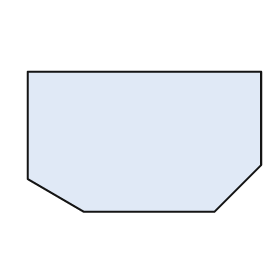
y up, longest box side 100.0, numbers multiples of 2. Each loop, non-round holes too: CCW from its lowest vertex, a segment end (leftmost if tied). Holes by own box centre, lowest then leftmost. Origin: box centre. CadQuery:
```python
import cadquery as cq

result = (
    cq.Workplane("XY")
    .moveTo(-26.0, -30.0)
    .lineTo(30.0, -30.0)
    .lineTo(50.0, -10.0)
    .lineTo(50.0, 30.0)
    .lineTo(-50.0, 30.0)
    .lineTo(-50.0, -16.0)
    .close()
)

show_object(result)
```